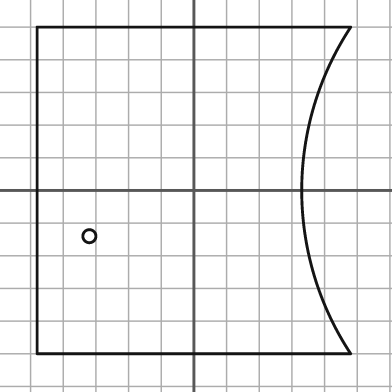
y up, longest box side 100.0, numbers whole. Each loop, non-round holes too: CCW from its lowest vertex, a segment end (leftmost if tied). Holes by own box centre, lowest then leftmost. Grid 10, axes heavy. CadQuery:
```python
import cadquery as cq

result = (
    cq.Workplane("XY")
    .moveTo(-48.0, -50.0)
    .lineTo(48.0, -50.0)
    .threePointArc((33.0, 0.0), (48.0, 50.0))
    .lineTo(-48.0, 50.0)
    .close()
    .moveTo(-32.0, -14.0)
    .circle(2.0)
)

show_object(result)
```